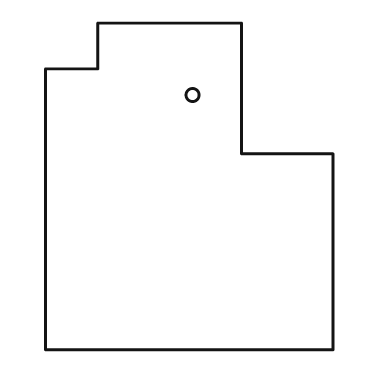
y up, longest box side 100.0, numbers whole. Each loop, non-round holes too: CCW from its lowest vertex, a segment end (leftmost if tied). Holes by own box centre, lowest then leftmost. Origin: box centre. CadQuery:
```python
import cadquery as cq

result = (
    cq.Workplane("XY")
    .moveTo(-44.0, -50.0)
    .lineTo(44.0, -50.0)
    .lineTo(44.0, 10.0)
    .lineTo(16.0, 10.0)
    .lineTo(16.0, 50.0)
    .lineTo(-28.0, 50.0)
    .lineTo(-28.0, 36.0)
    .lineTo(-44.0, 36.0)
    .close()
    .moveTo(1.0, 28.0)
    .circle(2.0)
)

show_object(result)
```